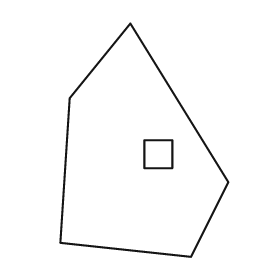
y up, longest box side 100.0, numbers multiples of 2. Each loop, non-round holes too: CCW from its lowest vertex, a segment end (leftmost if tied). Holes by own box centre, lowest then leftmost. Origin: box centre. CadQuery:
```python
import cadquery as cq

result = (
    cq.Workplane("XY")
    .moveTo(20.0, -50.0)
    .lineTo(36.0, -18.0)
    .lineTo(-6.0, 50.0)
    .lineTo(-32.0, 18.0)
    .lineTo(-36.0, -44.0)
    .close()
    .moveTo(0.0, -12.0)
    .lineTo(12.0, -12.0)
    .lineTo(12.0, 0.0)
    .lineTo(0.0, 0.0)
    .close()
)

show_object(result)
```